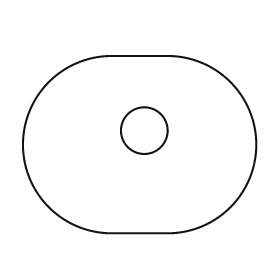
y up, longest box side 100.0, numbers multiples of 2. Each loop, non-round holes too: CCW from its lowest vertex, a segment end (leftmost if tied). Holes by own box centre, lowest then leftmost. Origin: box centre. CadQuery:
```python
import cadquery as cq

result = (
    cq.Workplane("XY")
    .moveTo(-12.0, -38.0)
    .lineTo(12.0, -38.0)
    .threePointArc((50.0, 0.0), (12.0, 38.0))
    .lineTo(-12.0, 38.0)
    .threePointArc((-50.0, 0.0), (-12.0, -38.0))
    .close()
    .moveTo(2.0, 6.0)
    .circle(10.0)
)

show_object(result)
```